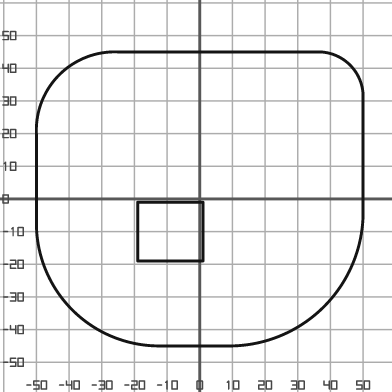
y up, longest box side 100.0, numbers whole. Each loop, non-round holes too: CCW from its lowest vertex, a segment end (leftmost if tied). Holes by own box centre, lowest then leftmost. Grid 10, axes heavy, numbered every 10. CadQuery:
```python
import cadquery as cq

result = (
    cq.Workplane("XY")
    .moveTo(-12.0, -45.0)
    .lineTo(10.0, -45.0)
    .threePointArc((38.0, -33.0), (50.0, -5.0))
    .lineTo(50.0, 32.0)
    .threePointArc((46.0, 41.0), (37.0, 45.0))
    .lineTo(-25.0, 45.0)
    .threePointArc((-43.0, 38.0), (-50.0, 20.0))
    .lineTo(-50.0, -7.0)
    .threePointArc((-39.0, -34.0), (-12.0, -45.0))
    .close()
    .moveTo(-19.0, -19.0)
    .lineTo(1.0, -19.0)
    .lineTo(1.0, -1.0)
    .lineTo(-19.0, -1.0)
    .close()
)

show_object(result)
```